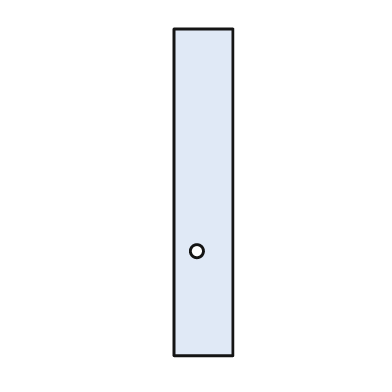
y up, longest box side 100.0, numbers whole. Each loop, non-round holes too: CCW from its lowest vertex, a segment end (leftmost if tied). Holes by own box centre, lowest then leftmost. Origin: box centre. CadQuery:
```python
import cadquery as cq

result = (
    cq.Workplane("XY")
    .moveTo(-9.0, -50.0)
    .lineTo(9.0, -50.0)
    .lineTo(9.0, 50.0)
    .lineTo(-9.0, 50.0)
    .close()
    .moveTo(-2.0, -18.0)
    .circle(2.0)
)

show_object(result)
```